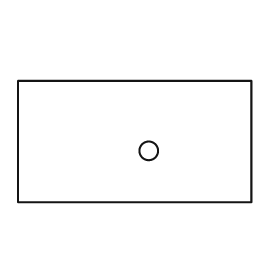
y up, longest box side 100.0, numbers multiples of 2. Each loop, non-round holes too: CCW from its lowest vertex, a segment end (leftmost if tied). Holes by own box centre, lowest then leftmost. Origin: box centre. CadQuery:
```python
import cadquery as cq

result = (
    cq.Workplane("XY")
    .moveTo(-50.0, -26.0)
    .lineTo(50.0, -26.0)
    .lineTo(50.0, 26.0)
    .lineTo(-50.0, 26.0)
    .close()
    .moveTo(6.0, -4.0)
    .circle(4.0)
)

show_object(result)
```